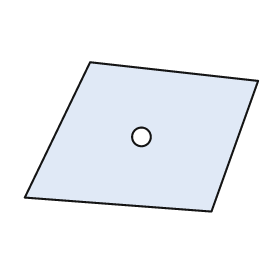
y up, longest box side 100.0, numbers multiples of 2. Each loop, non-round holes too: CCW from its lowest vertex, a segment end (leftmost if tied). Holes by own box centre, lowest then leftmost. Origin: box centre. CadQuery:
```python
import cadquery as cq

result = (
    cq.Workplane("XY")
    .moveTo(30.0, -32.0)
    .lineTo(50.0, 24.0)
    .lineTo(-22.0, 32.0)
    .lineTo(-50.0, -26.0)
    .close()
    .moveTo(0.0, 0.0)
    .circle(4.0)
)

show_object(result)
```